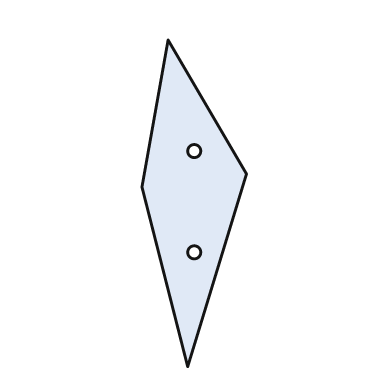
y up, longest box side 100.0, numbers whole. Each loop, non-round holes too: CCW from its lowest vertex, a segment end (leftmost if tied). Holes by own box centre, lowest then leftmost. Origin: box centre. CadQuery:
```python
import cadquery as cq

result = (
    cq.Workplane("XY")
    .moveTo(-2.0, -50.0)
    .lineTo(16.0, 9.0)
    .lineTo(-8.0, 50.0)
    .lineTo(-16.0, 5.0)
    .close()
    .moveTo(0.0, -15.0)
    .circle(2.0)
    .moveTo(0.0, 16.0)
    .circle(2.0)
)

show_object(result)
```